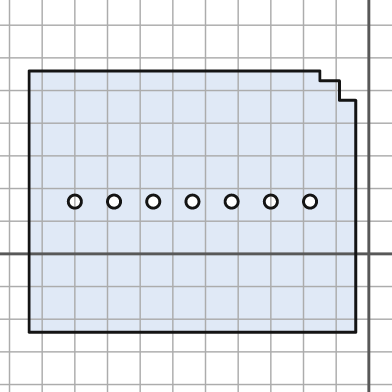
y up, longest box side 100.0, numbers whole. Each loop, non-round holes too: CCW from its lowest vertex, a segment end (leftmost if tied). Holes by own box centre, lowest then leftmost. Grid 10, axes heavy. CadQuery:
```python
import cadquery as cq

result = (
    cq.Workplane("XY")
    .moveTo(-104.0, -24.0)
    .lineTo(-4.0, -24.0)
    .lineTo(-4.0, 47.0)
    .lineTo(-9.0, 47.0)
    .lineTo(-9.0, 53.0)
    .lineTo(-15.0, 53.0)
    .lineTo(-15.0, 56.0)
    .lineTo(-104.0, 56.0)
    .close()
    .moveTo(-90.0, 16.0)
    .circle(2.0)
    .moveTo(-78.0, 16.0)
    .circle(2.0)
    .moveTo(-66.0, 16.0)
    .circle(2.0)
    .moveTo(-54.0, 16.0)
    .circle(2.0)
    .moveTo(-42.0, 16.0)
    .circle(2.0)
    .moveTo(-30.0, 16.0)
    .circle(2.0)
    .moveTo(-18.0, 16.0)
    .circle(2.0)
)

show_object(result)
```